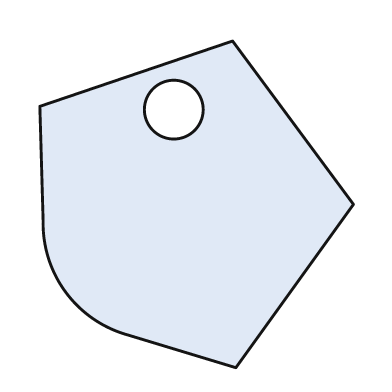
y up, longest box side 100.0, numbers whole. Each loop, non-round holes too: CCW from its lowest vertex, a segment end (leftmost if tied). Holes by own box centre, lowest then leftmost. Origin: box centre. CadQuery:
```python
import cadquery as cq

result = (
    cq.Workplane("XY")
    .moveTo(12.0, -50.0)
    .lineTo(48.0, 0.0)
    .lineTo(11.0, 50.0)
    .lineTo(-48.0, 30.0)
    .lineTo(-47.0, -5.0)
    .threePointArc((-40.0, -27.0), (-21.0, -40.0))
    .close()
    .moveTo(-7.0, 29.0)
    .circle(9.0)
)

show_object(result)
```